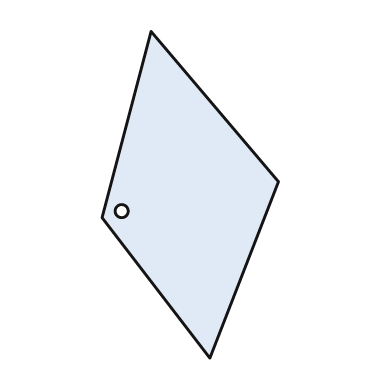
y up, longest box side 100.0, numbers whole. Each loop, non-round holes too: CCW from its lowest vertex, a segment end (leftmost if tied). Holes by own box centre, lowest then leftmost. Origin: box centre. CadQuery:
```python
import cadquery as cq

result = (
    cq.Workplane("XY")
    .moveTo(6.0, -50.0)
    .lineTo(27.0, 4.0)
    .lineTo(-12.0, 50.0)
    .lineTo(-27.0, -7.0)
    .close()
    .moveTo(-21.0, -5.0)
    .circle(2.0)
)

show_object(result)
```